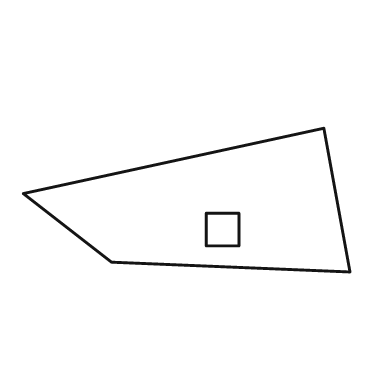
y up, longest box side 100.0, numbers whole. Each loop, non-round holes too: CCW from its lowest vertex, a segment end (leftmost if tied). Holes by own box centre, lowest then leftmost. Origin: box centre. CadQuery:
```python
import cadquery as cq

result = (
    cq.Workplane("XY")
    .moveTo(50.0, -22.0)
    .lineTo(42.0, 22.0)
    .lineTo(-50.0, 2.0)
    .lineTo(-23.0, -19.0)
    .close()
    .moveTo(6.0, -14.0)
    .lineTo(16.0, -14.0)
    .lineTo(16.0, -4.0)
    .lineTo(6.0, -4.0)
    .close()
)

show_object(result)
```